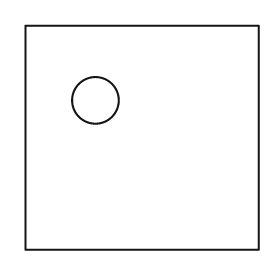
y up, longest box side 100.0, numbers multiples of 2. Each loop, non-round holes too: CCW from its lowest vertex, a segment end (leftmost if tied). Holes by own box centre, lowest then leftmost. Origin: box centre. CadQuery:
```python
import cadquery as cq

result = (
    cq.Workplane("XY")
    .moveTo(-50.0, -48.0)
    .lineTo(50.0, -48.0)
    .lineTo(50.0, 48.0)
    .lineTo(-50.0, 48.0)
    .close()
    .moveTo(-20.0, 16.0)
    .circle(10.0)
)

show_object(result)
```